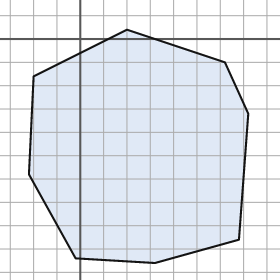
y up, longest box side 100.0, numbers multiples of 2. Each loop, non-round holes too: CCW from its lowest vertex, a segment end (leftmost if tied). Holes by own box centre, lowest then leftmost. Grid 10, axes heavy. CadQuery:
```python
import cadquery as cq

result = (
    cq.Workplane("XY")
    .moveTo(32.0, -96.0)
    .lineTo(68.0, -86.0)
    .lineTo(72.0, -32.0)
    .lineTo(62.0, -10.0)
    .lineTo(20.0, 4.0)
    .lineTo(-20.0, -16.0)
    .lineTo(-22.0, -58.0)
    .lineTo(-2.0, -94.0)
    .close()
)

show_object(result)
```